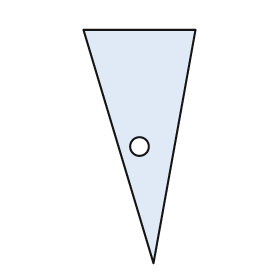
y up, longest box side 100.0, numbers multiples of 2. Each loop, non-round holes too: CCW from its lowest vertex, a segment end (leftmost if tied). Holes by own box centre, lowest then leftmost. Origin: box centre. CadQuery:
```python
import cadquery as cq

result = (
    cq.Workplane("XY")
    .moveTo(6.0, -50.0)
    .lineTo(24.0, 50.0)
    .lineTo(-24.0, 50.0)
    .close()
    .moveTo(0.0, 0.0)
    .circle(4.0)
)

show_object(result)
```